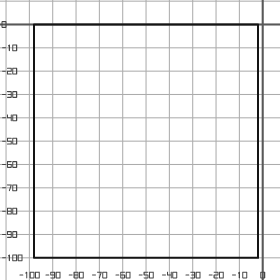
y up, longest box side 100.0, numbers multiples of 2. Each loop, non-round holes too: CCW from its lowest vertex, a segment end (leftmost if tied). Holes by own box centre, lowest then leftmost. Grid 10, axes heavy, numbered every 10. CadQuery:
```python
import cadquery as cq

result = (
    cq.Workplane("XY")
    .moveTo(-98.0, -100.0)
    .lineTo(-2.0, -100.0)
    .lineTo(-2.0, 0.0)
    .lineTo(-98.0, 0.0)
    .close()
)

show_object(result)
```